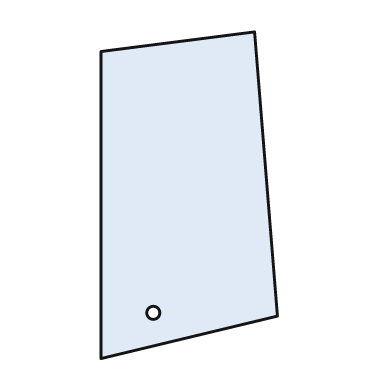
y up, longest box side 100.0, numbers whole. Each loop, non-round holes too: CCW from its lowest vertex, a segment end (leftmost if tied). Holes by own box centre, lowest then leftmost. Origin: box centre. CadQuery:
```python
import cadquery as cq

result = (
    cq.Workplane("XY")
    .moveTo(-27.0, -50.0)
    .lineTo(27.0, -37.0)
    .lineTo(20.0, 50.0)
    .lineTo(-27.0, 44.0)
    .close()
    .moveTo(-11.0, -36.0)
    .circle(2.0)
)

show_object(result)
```